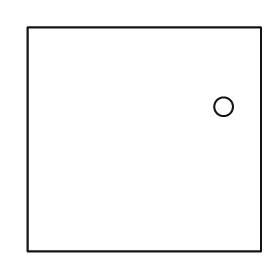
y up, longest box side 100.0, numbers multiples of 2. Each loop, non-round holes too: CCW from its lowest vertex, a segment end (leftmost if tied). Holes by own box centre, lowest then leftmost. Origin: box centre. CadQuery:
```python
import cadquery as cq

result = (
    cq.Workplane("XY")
    .moveTo(-50.0, -48.0)
    .lineTo(50.0, -48.0)
    .lineTo(50.0, 48.0)
    .lineTo(-50.0, 48.0)
    .close()
    .moveTo(34.0, 14.0)
    .circle(4.0)
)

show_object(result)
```